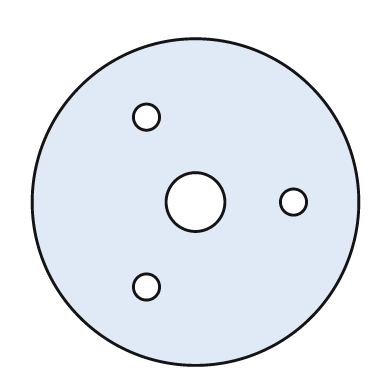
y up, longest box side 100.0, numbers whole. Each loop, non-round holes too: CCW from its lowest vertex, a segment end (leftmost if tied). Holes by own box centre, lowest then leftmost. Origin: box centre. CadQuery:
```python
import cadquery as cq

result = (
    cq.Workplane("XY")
    .moveTo(0.0, 0.0)
    .circle(50.0)
    .moveTo(-15.0, -26.0)
    .circle(4.0)
    .moveTo(0.0, 0.0)
    .circle(9.0)
    .moveTo(30.0, 0.0)
    .circle(4.0)
    .moveTo(-15.0, 26.0)
    .circle(4.0)
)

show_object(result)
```